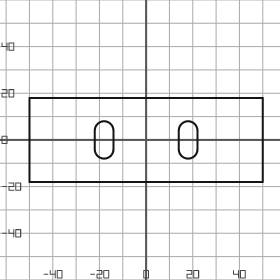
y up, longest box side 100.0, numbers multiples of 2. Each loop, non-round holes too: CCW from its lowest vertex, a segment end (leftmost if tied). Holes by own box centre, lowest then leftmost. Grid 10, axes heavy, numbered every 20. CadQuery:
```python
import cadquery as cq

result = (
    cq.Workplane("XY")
    .moveTo(-50.0, -18.0)
    .lineTo(50.0, -18.0)
    .lineTo(50.0, 18.0)
    .lineTo(-50.0, 18.0)
    .close()
    .moveTo(-22.0, -4.0)
    .threePointArc((-18.0, -8.0), (-14.0, -4.0))
    .lineTo(-14.0, 4.0)
    .threePointArc((-18.0, 8.0), (-22.0, 4.0))
    .close()
    .moveTo(14.0, -4.0)
    .threePointArc((18.0, -8.0), (22.0, -4.0))
    .lineTo(22.0, 4.0)
    .threePointArc((18.0, 8.0), (14.0, 4.0))
    .close()
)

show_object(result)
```